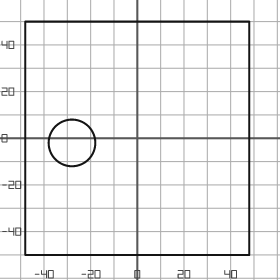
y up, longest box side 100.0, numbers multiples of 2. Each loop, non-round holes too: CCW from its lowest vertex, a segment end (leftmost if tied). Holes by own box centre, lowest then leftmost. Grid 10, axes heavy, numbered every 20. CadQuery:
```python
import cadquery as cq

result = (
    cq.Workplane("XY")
    .moveTo(-48.0, -50.0)
    .lineTo(48.0, -50.0)
    .lineTo(48.0, 50.0)
    .lineTo(-48.0, 50.0)
    .close()
    .moveTo(-28.0, -2.0)
    .circle(10.0)
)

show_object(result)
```